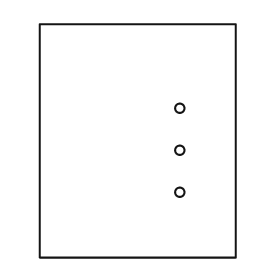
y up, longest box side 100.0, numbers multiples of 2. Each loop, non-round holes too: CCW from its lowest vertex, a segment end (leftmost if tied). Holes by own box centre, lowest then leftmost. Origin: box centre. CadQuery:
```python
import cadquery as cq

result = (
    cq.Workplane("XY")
    .moveTo(-42.0, -50.0)
    .lineTo(42.0, -50.0)
    .lineTo(42.0, 50.0)
    .lineTo(-42.0, 50.0)
    .close()
    .moveTo(18.0, -22.0)
    .circle(2.0)
    .moveTo(18.0, -4.0)
    .circle(2.0)
    .moveTo(18.0, 14.0)
    .circle(2.0)
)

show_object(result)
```